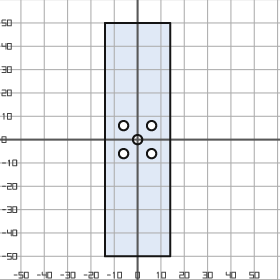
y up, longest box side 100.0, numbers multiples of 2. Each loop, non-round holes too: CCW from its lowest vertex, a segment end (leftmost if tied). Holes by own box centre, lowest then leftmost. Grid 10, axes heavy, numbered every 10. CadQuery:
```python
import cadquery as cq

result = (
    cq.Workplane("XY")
    .moveTo(-14.0, -50.0)
    .lineTo(14.0, -50.0)
    .lineTo(14.0, 50.0)
    .lineTo(-14.0, 50.0)
    .close()
    .moveTo(-6.0, -6.0)
    .circle(2.0)
    .moveTo(6.0, -6.0)
    .circle(2.0)
    .moveTo(0.0, 0.0)
    .circle(2.0)
    .moveTo(-6.0, 6.0)
    .circle(2.0)
    .moveTo(6.0, 6.0)
    .circle(2.0)
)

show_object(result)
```